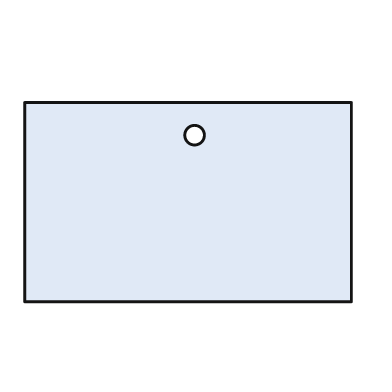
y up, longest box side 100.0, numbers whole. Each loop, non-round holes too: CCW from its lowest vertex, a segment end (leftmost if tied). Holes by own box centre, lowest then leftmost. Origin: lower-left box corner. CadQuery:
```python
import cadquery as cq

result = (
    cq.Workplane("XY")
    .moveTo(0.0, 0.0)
    .lineTo(100.0, 0.0)
    .lineTo(100.0, 61.0)
    .lineTo(0.0, 61.0)
    .close()
    .moveTo(52.0, 51.0)
    .circle(3.0)
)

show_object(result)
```